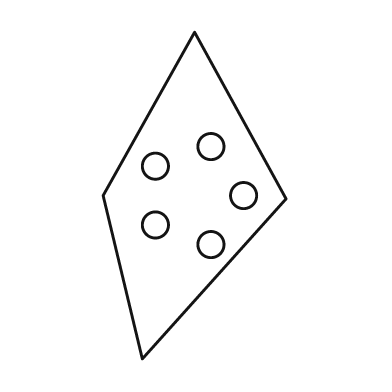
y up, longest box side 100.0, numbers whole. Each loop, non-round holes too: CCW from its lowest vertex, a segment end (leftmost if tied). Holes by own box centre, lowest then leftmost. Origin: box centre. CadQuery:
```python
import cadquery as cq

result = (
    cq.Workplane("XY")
    .moveTo(-16.0, -50.0)
    .lineTo(28.0, -1.0)
    .lineTo(0.0, 50.0)
    .lineTo(-28.0, 0.0)
    .close()
    .moveTo(5.0, -15.0)
    .circle(4.0)
    .moveTo(-12.0, -9.0)
    .circle(4.0)
    .moveTo(15.0, 0.0)
    .circle(4.0)
    .moveTo(-12.0, 9.0)
    .circle(4.0)
    .moveTo(5.0, 15.0)
    .circle(4.0)
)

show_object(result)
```